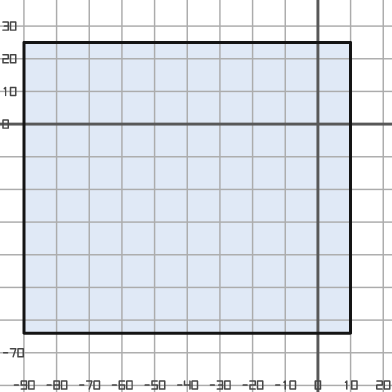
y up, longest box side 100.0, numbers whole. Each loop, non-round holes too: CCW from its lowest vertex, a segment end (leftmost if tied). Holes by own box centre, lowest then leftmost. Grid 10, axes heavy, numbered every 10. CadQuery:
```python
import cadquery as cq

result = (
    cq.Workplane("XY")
    .moveTo(-90.0, -64.0)
    .lineTo(10.0, -64.0)
    .lineTo(10.0, 25.0)
    .lineTo(-90.0, 25.0)
    .close()
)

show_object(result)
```